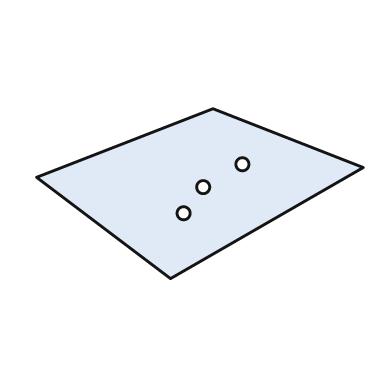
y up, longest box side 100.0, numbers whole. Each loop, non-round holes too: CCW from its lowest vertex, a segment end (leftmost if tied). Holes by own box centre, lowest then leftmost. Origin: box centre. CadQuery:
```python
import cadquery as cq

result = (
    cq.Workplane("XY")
    .moveTo(-9.0, -26.0)
    .lineTo(50.0, 8.0)
    .lineTo(4.0, 26.0)
    .lineTo(-50.0, 5.0)
    .close()
    .moveTo(-5.0, -6.0)
    .circle(2.0)
    .moveTo(1.0, 2.0)
    .circle(2.0)
    .moveTo(13.0, 9.0)
    .circle(2.0)
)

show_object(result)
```